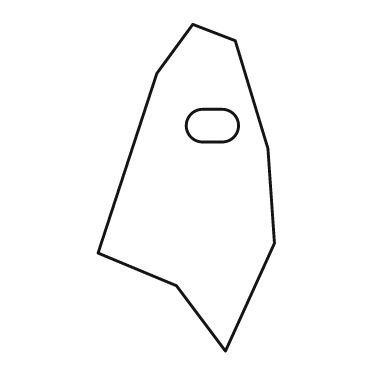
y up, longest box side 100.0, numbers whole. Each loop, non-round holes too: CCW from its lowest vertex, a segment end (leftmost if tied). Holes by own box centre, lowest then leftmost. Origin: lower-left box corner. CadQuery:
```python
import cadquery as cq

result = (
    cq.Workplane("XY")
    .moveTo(39.0, 0.0)
    .lineTo(54.0, 33.0)
    .lineTo(52.0, 62.0)
    .lineTo(42.0, 95.0)
    .lineTo(29.0, 100.0)
    .lineTo(18.0, 85.0)
    .lineTo(0.0, 30.0)
    .lineTo(24.0, 20.0)
    .close()
    .moveTo(32.0, 64.0)
    .lineTo(38.0, 64.0)
    .threePointArc((43.0, 69.0), (38.0, 74.0))
    .lineTo(32.0, 74.0)
    .threePointArc((27.0, 69.0), (32.0, 64.0))
    .close()
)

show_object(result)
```